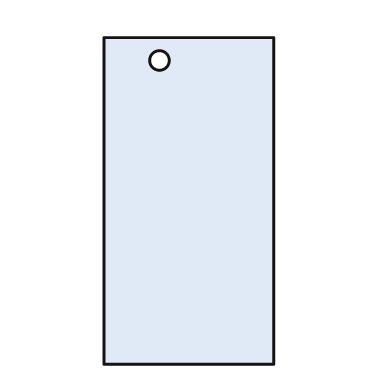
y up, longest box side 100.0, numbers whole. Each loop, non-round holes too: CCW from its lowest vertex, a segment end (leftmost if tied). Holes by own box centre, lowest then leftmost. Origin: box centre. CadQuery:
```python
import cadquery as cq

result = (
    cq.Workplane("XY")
    .moveTo(-26.0, -50.0)
    .lineTo(26.0, -50.0)
    .lineTo(26.0, 50.0)
    .lineTo(-26.0, 50.0)
    .close()
    .moveTo(-9.0, 43.0)
    .circle(3.0)
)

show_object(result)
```